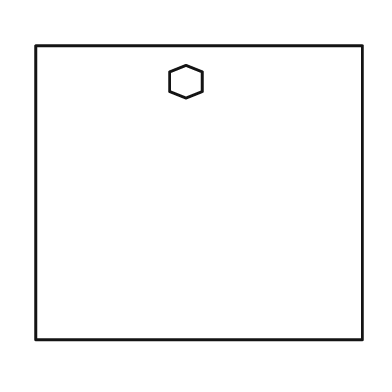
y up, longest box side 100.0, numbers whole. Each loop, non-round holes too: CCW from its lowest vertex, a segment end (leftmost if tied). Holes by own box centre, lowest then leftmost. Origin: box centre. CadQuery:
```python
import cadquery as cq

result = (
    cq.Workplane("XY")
    .moveTo(-50.0, -45.0)
    .lineTo(50.0, -45.0)
    .lineTo(50.0, 45.0)
    .lineTo(-50.0, 45.0)
    .close()
    .moveTo(-4.0, 29.0)
    .lineTo(1.0, 31.0)
    .lineTo(1.0, 37.0)
    .lineTo(-4.0, 39.0)
    .lineTo(-9.0, 37.0)
    .lineTo(-9.0, 31.0)
    .close()
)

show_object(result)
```